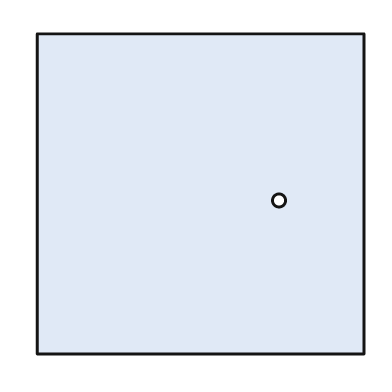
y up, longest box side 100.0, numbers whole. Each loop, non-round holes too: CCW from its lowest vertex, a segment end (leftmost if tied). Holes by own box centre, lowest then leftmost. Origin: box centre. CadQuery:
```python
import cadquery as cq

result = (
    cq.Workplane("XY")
    .moveTo(-50.0, -49.0)
    .lineTo(50.0, -49.0)
    .lineTo(50.0, 49.0)
    .lineTo(-50.0, 49.0)
    .close()
    .moveTo(24.0, -2.0)
    .circle(2.0)
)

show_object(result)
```